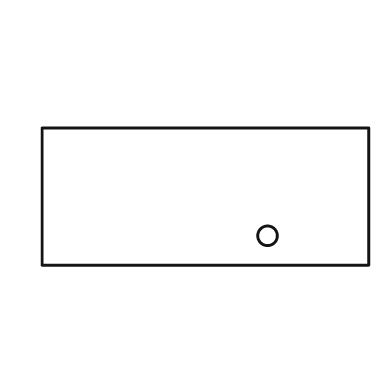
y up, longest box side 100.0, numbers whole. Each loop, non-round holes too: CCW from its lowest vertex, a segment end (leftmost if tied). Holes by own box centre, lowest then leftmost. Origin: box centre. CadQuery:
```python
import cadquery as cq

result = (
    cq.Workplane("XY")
    .moveTo(-50.0, -21.0)
    .lineTo(50.0, -21.0)
    .lineTo(50.0, 21.0)
    .lineTo(-50.0, 21.0)
    .close()
    .moveTo(19.0, -12.0)
    .circle(3.0)
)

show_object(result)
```